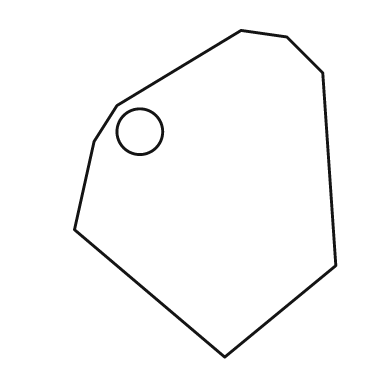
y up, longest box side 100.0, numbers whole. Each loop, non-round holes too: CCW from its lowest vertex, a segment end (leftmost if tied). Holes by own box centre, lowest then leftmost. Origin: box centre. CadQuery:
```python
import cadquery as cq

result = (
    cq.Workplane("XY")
    .moveTo(6.0, -50.0)
    .lineTo(40.0, -22.0)
    .lineTo(36.0, 37.0)
    .lineTo(25.0, 48.0)
    .lineTo(11.0, 50.0)
    .lineTo(-27.0, 27.0)
    .lineTo(-34.0, 16.0)
    .lineTo(-40.0, -11.0)
    .close()
    .moveTo(-20.0, 19.0)
    .circle(7.0)
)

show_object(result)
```